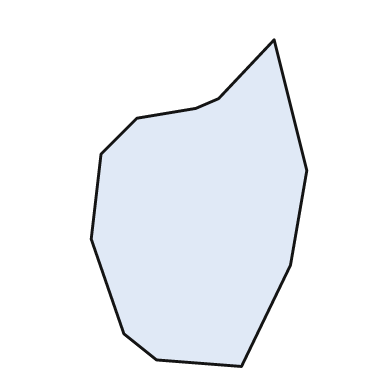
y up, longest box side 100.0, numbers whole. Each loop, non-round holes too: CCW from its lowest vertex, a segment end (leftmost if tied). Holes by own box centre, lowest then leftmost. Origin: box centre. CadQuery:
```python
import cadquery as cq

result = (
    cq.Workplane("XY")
    .moveTo(13.0, -50.0)
    .lineTo(28.0, -19.0)
    .lineTo(33.0, 10.0)
    .lineTo(23.0, 50.0)
    .lineTo(6.0, 32.0)
    .lineTo(-1.0, 29.0)
    .lineTo(-19.0, 26.0)
    .lineTo(-30.0, 15.0)
    .lineTo(-33.0, -11.0)
    .lineTo(-23.0, -40.0)
    .lineTo(-13.0, -48.0)
    .close()
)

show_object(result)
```